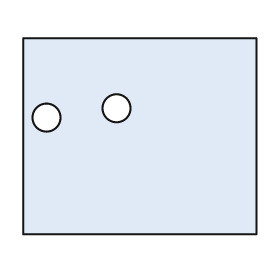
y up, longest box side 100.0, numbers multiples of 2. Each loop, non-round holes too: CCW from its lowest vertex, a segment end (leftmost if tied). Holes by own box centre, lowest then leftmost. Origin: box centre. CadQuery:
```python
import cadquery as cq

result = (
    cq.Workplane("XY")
    .moveTo(-50.0, -42.0)
    .lineTo(50.0, -42.0)
    .lineTo(50.0, 42.0)
    .lineTo(-50.0, 42.0)
    .close()
    .moveTo(-40.0, 8.0)
    .circle(6.0)
    .moveTo(-10.0, 12.0)
    .circle(6.0)
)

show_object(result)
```